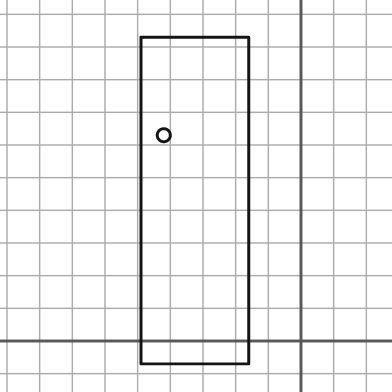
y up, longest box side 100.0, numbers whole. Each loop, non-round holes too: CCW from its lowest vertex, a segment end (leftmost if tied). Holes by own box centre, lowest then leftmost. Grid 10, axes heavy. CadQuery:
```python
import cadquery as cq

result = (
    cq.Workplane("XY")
    .moveTo(-49.0, -7.0)
    .lineTo(-16.0, -7.0)
    .lineTo(-16.0, 93.0)
    .lineTo(-49.0, 93.0)
    .close()
    .moveTo(-42.0, 63.0)
    .circle(2.0)
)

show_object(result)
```